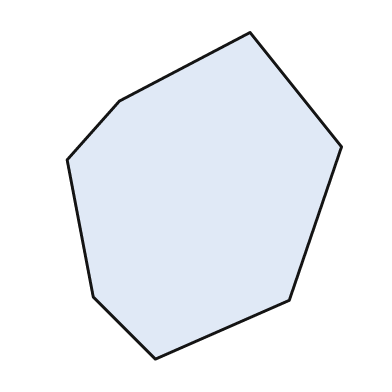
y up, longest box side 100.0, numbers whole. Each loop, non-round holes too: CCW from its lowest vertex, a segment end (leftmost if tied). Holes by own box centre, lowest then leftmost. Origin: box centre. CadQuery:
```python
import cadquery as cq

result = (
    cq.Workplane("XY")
    .moveTo(-15.0, -50.0)
    .lineTo(26.0, -32.0)
    .lineTo(42.0, 15.0)
    .lineTo(14.0, 50.0)
    .lineTo(-26.0, 29.0)
    .lineTo(-42.0, 11.0)
    .lineTo(-34.0, -31.0)
    .close()
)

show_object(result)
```